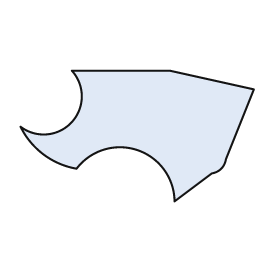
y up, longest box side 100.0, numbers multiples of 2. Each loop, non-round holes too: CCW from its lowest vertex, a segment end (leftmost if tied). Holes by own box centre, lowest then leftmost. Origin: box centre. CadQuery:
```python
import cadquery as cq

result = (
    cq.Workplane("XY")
    .moveTo(16.0, -28.0)
    .lineTo(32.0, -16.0)
    .threePointArc((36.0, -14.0), (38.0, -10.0))
    .lineTo(50.0, 20.0)
    .lineTo(14.0, 28.0)
    .lineTo(-28.0, 28.0)
    .threePointArc((-28.0, 6.0), (-50.0, 4.0))
    .threePointArc((-40.0, -8.0), (-26.0, -14.0))
    .threePointArc((0.0, -6.0), (16.0, -28.0))
    .close()
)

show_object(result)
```